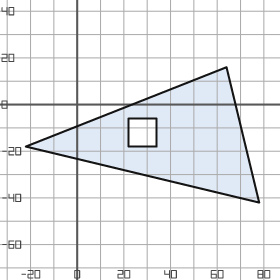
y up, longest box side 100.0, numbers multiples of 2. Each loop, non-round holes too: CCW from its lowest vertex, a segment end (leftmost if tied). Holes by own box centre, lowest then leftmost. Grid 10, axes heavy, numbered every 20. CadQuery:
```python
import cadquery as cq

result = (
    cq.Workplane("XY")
    .moveTo(78.0, -42.0)
    .lineTo(64.0, 16.0)
    .lineTo(-22.0, -18.0)
    .close()
    .moveTo(22.0, -18.0)
    .lineTo(34.0, -18.0)
    .lineTo(34.0, -6.0)
    .lineTo(22.0, -6.0)
    .close()
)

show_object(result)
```